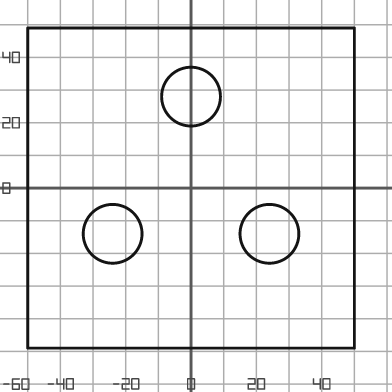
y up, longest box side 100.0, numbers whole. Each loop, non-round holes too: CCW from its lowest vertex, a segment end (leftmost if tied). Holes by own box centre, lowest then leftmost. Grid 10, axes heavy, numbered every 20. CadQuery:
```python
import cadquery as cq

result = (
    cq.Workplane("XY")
    .moveTo(-50.0, -49.0)
    .lineTo(50.0, -49.0)
    .lineTo(50.0, 49.0)
    .lineTo(-50.0, 49.0)
    .close()
    .moveTo(-24.0, -14.0)
    .circle(9.0)
    .moveTo(24.0, -14.0)
    .circle(9.0)
    .moveTo(0.0, 28.0)
    .circle(9.0)
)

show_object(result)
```